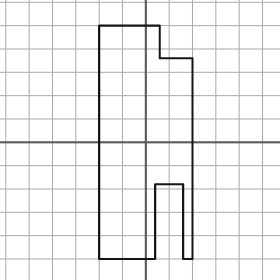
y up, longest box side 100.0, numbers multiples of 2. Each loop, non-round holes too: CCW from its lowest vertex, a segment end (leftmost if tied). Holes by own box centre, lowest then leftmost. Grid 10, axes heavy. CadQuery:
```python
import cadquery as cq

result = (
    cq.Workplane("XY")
    .moveTo(-20.0, -50.0)
    .lineTo(4.0, -50.0)
    .lineTo(4.0, -18.0)
    .lineTo(16.0, -18.0)
    .lineTo(16.0, -50.0)
    .lineTo(20.0, -50.0)
    .lineTo(20.0, 36.0)
    .lineTo(6.0, 36.0)
    .lineTo(6.0, 50.0)
    .lineTo(-20.0, 50.0)
    .close()
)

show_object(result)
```